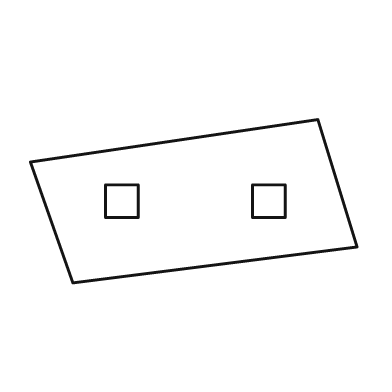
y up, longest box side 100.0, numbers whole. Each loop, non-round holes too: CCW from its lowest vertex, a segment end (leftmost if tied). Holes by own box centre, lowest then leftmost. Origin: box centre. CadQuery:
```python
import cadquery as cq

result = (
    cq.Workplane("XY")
    .moveTo(-37.0, -25.0)
    .lineTo(50.0, -14.0)
    .lineTo(38.0, 25.0)
    .lineTo(-50.0, 12.0)
    .close()
    .moveTo(-27.0, -5.0)
    .lineTo(-17.0, -5.0)
    .lineTo(-17.0, 5.0)
    .lineTo(-27.0, 5.0)
    .close()
    .moveTo(18.0, -5.0)
    .lineTo(28.0, -5.0)
    .lineTo(28.0, 5.0)
    .lineTo(18.0, 5.0)
    .close()
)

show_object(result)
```